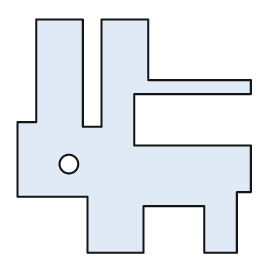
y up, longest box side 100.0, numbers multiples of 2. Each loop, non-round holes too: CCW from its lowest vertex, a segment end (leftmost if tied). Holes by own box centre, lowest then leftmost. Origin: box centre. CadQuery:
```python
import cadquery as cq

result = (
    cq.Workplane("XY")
    .moveTo(-20.0, -50.0)
    .lineTo(4.0, -50.0)
    .lineTo(4.0, -30.0)
    .lineTo(30.0, -30.0)
    .lineTo(30.0, -50.0)
    .lineTo(44.0, -50.0)
    .lineTo(44.0, -24.0)
    .lineTo(50.0, -24.0)
    .lineTo(50.0, -4.0)
    .lineTo(0.0, -4.0)
    .lineTo(0.0, 18.0)
    .lineTo(50.0, 18.0)
    .lineTo(50.0, 24.0)
    .lineTo(6.0, 24.0)
    .lineTo(6.0, 50.0)
    .lineTo(-14.0, 50.0)
    .lineTo(-14.0, 4.0)
    .lineTo(-22.0, 4.0)
    .lineTo(-22.0, 50.0)
    .lineTo(-42.0, 50.0)
    .lineTo(-42.0, 6.0)
    .lineTo(-50.0, 6.0)
    .lineTo(-50.0, -26.0)
    .lineTo(-20.0, -26.0)
    .close()
    .moveTo(-28.0, -12.0)
    .circle(4.0)
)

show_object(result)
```